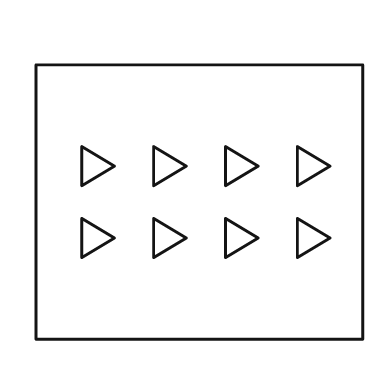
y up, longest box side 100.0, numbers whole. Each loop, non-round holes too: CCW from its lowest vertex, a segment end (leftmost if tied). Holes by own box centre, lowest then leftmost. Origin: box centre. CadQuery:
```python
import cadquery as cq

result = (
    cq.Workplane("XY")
    .moveTo(-50.0, -42.0)
    .lineTo(50.0, -42.0)
    .lineTo(50.0, 42.0)
    .lineTo(-50.0, 42.0)
    .close()
    .moveTo(-36.0, -17.0)
    .lineTo(-26.0, -11.0)
    .lineTo(-36.0, -5.0)
    .close()
    .moveTo(-14.0, -17.0)
    .lineTo(-4.0, -11.0)
    .lineTo(-14.0, -5.0)
    .close()
    .moveTo(8.0, -17.0)
    .lineTo(18.0, -11.0)
    .lineTo(8.0, -5.0)
    .close()
    .moveTo(30.0, -17.0)
    .lineTo(40.0, -11.0)
    .lineTo(30.0, -5.0)
    .close()
    .moveTo(-36.0, 5.0)
    .lineTo(-26.0, 11.0)
    .lineTo(-36.0, 17.0)
    .close()
    .moveTo(-14.0, 5.0)
    .lineTo(-4.0, 11.0)
    .lineTo(-14.0, 17.0)
    .close()
    .moveTo(8.0, 5.0)
    .lineTo(18.0, 11.0)
    .lineTo(8.0, 17.0)
    .close()
    .moveTo(30.0, 5.0)
    .lineTo(40.0, 11.0)
    .lineTo(30.0, 17.0)
    .close()
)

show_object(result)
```